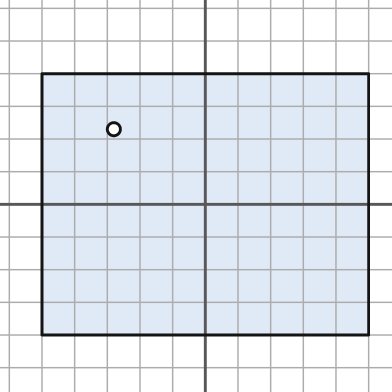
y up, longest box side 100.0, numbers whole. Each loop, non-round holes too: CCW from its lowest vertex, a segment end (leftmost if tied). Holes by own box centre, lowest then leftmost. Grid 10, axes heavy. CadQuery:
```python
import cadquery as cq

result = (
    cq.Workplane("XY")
    .moveTo(-50.0, -40.0)
    .lineTo(50.0, -40.0)
    .lineTo(50.0, 40.0)
    .lineTo(-50.0, 40.0)
    .close()
    .moveTo(-28.0, 23.0)
    .circle(2.0)
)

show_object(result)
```